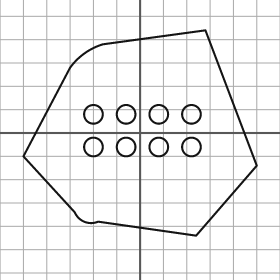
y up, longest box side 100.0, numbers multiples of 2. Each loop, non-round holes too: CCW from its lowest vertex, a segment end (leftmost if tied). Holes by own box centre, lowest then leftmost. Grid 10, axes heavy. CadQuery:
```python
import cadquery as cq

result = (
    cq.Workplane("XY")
    .moveTo(24.0, -44.0)
    .lineTo(50.0, -14.0)
    .lineTo(28.0, 44.0)
    .lineTo(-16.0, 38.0)
    .threePointArc((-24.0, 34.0), (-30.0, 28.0))
    .lineTo(-50.0, -10.0)
    .lineTo(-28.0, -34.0)
    .threePointArc((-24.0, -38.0), (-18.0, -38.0))
    .close()
    .moveTo(-20.0, -6.0)
    .circle(4.0)
    .moveTo(-6.0, -6.0)
    .circle(4.0)
    .moveTo(8.0, -6.0)
    .circle(4.0)
    .moveTo(22.0, -6.0)
    .circle(4.0)
    .moveTo(-20.0, 8.0)
    .circle(4.0)
    .moveTo(-6.0, 8.0)
    .circle(4.0)
    .moveTo(8.0, 8.0)
    .circle(4.0)
    .moveTo(22.0, 8.0)
    .circle(4.0)
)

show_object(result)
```